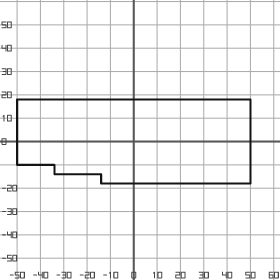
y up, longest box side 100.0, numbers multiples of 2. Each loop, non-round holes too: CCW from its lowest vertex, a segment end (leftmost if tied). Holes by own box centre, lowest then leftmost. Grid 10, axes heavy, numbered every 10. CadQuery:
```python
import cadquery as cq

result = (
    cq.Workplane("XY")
    .moveTo(-14.0, -18.0)
    .lineTo(50.0, -18.0)
    .lineTo(50.0, 18.0)
    .lineTo(-50.0, 18.0)
    .lineTo(-50.0, -10.0)
    .lineTo(-34.0, -10.0)
    .lineTo(-34.0, -14.0)
    .lineTo(-14.0, -14.0)
    .close()
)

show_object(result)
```